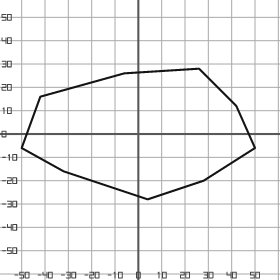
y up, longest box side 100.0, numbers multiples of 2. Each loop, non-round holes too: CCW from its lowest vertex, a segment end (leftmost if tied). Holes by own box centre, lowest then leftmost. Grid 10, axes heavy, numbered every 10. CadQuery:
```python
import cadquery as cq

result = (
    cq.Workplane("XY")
    .moveTo(4.0, -28.0)
    .lineTo(28.0, -20.0)
    .lineTo(50.0, -6.0)
    .lineTo(42.0, 12.0)
    .lineTo(26.0, 28.0)
    .lineTo(-6.0, 26.0)
    .lineTo(-42.0, 16.0)
    .lineTo(-50.0, -6.0)
    .lineTo(-32.0, -16.0)
    .close()
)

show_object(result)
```